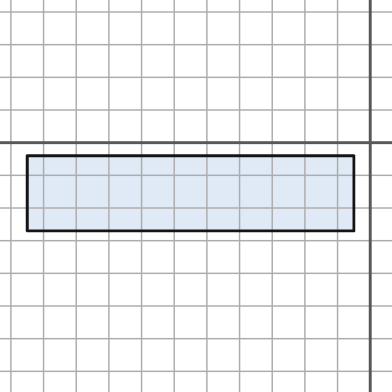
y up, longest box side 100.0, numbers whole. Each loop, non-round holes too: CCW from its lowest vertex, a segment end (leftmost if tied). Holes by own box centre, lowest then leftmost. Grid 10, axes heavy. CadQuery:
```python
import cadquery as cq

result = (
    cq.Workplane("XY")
    .moveTo(-105.0, -27.0)
    .lineTo(-5.0, -27.0)
    .lineTo(-5.0, -4.0)
    .lineTo(-105.0, -4.0)
    .close()
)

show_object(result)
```